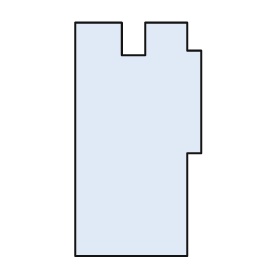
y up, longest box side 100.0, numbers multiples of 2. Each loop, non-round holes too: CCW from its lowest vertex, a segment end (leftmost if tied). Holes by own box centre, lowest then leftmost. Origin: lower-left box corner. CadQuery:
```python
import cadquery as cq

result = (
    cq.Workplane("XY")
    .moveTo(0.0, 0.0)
    .lineTo(48.0, 0.0)
    .lineTo(48.0, 44.0)
    .lineTo(54.0, 44.0)
    .lineTo(54.0, 88.0)
    .lineTo(48.0, 88.0)
    .lineTo(48.0, 100.0)
    .lineTo(30.0, 100.0)
    .lineTo(30.0, 86.0)
    .lineTo(20.0, 86.0)
    .lineTo(20.0, 100.0)
    .lineTo(0.0, 100.0)
    .close()
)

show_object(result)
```